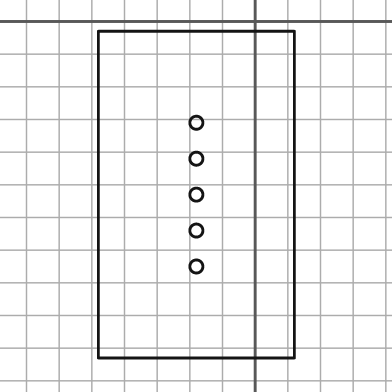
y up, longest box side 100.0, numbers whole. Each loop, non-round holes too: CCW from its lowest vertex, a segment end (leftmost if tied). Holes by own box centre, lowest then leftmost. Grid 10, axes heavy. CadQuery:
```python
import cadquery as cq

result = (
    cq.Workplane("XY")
    .moveTo(-48.0, -103.0)
    .lineTo(12.0, -103.0)
    .lineTo(12.0, -3.0)
    .lineTo(-48.0, -3.0)
    .close()
    .moveTo(-18.0, -75.0)
    .circle(2.0)
    .moveTo(-18.0, -64.0)
    .circle(2.0)
    .moveTo(-18.0, -53.0)
    .circle(2.0)
    .moveTo(-18.0, -42.0)
    .circle(2.0)
    .moveTo(-18.0, -31.0)
    .circle(2.0)
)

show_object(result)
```